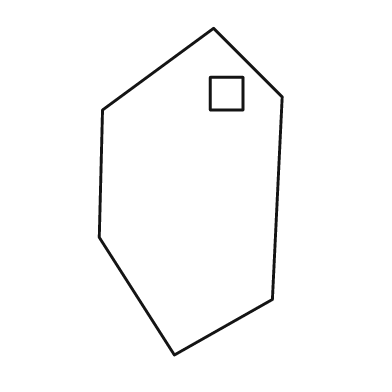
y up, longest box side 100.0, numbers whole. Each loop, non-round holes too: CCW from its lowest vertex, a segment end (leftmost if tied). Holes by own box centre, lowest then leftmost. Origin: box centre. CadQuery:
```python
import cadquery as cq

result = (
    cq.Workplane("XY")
    .moveTo(-5.0, -50.0)
    .lineTo(25.0, -33.0)
    .lineTo(28.0, 29.0)
    .lineTo(7.0, 50.0)
    .lineTo(-27.0, 25.0)
    .lineTo(-28.0, -14.0)
    .close()
    .moveTo(6.0, 25.0)
    .lineTo(16.0, 25.0)
    .lineTo(16.0, 35.0)
    .lineTo(6.0, 35.0)
    .close()
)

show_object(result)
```